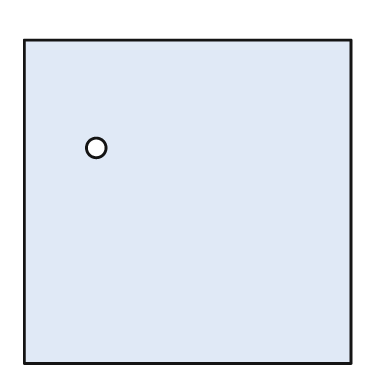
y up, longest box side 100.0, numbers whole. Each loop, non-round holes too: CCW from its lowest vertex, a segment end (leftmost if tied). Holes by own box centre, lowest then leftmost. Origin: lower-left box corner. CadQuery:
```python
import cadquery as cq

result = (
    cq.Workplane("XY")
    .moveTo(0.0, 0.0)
    .lineTo(100.0, 0.0)
    .lineTo(100.0, 99.0)
    .lineTo(0.0, 99.0)
    .close()
    .moveTo(22.0, 66.0)
    .circle(3.0)
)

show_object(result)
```